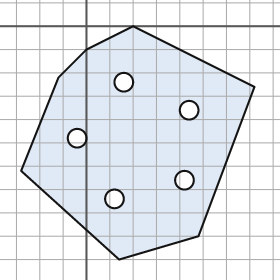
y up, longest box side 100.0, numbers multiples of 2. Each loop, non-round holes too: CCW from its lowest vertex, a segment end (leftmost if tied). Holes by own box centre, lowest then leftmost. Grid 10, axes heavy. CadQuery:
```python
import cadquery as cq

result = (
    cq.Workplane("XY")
    .moveTo(14.0, -100.0)
    .lineTo(48.0, -90.0)
    .lineTo(72.0, -26.0)
    .lineTo(20.0, 0.0)
    .lineTo(0.0, -10.0)
    .lineTo(-12.0, -22.0)
    .lineTo(-28.0, -62.0)
    .close()
    .moveTo(12.0, -74.0)
    .circle(4.0)
    .moveTo(42.0, -66.0)
    .circle(4.0)
    .moveTo(-4.0, -48.0)
    .circle(4.0)
    .moveTo(44.0, -36.0)
    .circle(4.0)
    .moveTo(16.0, -24.0)
    .circle(4.0)
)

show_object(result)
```